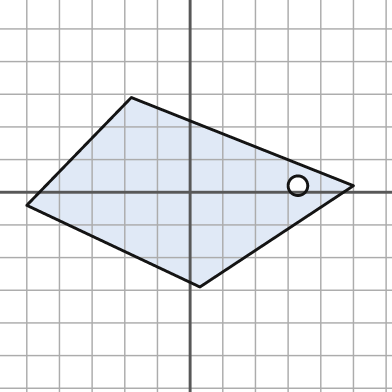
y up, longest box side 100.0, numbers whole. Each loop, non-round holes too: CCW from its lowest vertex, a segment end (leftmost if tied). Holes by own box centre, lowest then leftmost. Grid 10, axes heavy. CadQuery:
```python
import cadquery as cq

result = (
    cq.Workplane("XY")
    .moveTo(3.0, -29.0)
    .lineTo(50.0, 2.0)
    .lineTo(-18.0, 29.0)
    .lineTo(-50.0, -4.0)
    .close()
    .moveTo(33.0, 2.0)
    .circle(3.0)
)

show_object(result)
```